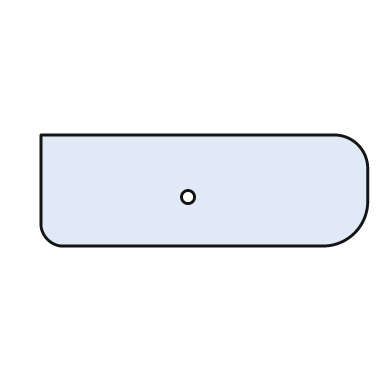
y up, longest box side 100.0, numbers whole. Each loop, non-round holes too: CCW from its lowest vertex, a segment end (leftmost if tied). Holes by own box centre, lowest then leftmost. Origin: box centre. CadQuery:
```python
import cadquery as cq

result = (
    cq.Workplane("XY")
    .moveTo(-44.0, -17.0)
    .lineTo(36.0, -17.0)
    .threePointArc((46.0, -13.0), (50.0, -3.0))
    .lineTo(50.0, 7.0)
    .threePointArc((47.0, 14.0), (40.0, 17.0))
    .lineTo(-50.0, 17.0)
    .lineTo(-50.0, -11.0)
    .threePointArc((-48.0, -15.0), (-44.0, -17.0))
    .close()
    .moveTo(-5.0, -2.0)
    .circle(2.0)
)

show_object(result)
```